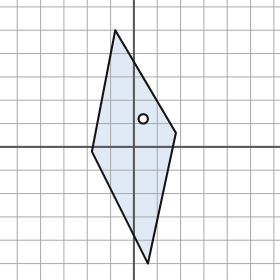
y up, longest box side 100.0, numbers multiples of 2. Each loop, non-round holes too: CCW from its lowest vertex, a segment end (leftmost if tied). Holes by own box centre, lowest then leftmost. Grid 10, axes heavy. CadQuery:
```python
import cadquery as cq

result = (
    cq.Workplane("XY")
    .moveTo(6.0, -50.0)
    .lineTo(18.0, 6.0)
    .lineTo(-8.0, 50.0)
    .lineTo(-18.0, -2.0)
    .close()
    .moveTo(4.0, 12.0)
    .circle(2.0)
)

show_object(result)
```